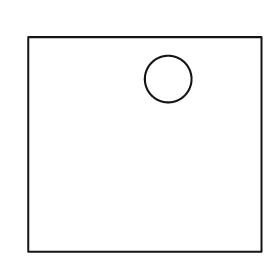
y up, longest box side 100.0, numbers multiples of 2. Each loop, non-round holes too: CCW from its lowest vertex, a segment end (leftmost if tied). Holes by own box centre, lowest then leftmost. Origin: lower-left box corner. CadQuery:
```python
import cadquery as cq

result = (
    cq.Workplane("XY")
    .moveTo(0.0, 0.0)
    .lineTo(100.0, 0.0)
    .lineTo(100.0, 92.0)
    .lineTo(0.0, 92.0)
    .close()
    .moveTo(60.0, 74.0)
    .circle(10.0)
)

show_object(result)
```